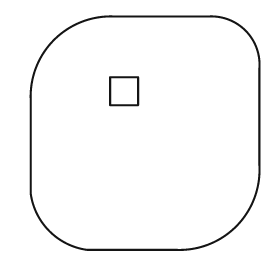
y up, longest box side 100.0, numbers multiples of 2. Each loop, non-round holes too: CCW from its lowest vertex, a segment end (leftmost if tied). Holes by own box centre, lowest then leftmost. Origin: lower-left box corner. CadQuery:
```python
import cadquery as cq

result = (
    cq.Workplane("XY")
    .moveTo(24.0, 0.0)
    .lineTo(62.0, 0.0)
    .threePointArc((88.0, 10.0), (98.0, 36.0))
    .lineTo(98.0, 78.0)
    .threePointArc((92.0, 94.0), (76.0, 100.0))
    .lineTo(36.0, 100.0)
    .threePointArc((10.0, 90.0), (0.0, 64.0))
    .lineTo(0.0, 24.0)
    .threePointArc((8.0, 8.0), (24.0, 0.0))
    .close()
    .moveTo(34.0, 62.0)
    .lineTo(46.0, 62.0)
    .lineTo(46.0, 74.0)
    .lineTo(34.0, 74.0)
    .close()
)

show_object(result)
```